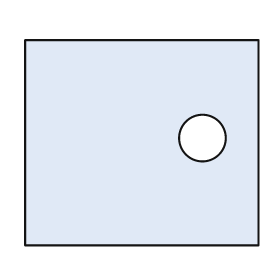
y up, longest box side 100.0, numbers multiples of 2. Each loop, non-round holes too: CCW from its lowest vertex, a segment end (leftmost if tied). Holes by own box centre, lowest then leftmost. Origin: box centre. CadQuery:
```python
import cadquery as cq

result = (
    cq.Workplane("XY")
    .moveTo(-50.0, -44.0)
    .lineTo(50.0, -44.0)
    .lineTo(50.0, 44.0)
    .lineTo(-50.0, 44.0)
    .close()
    .moveTo(26.0, 2.0)
    .circle(10.0)
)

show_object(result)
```